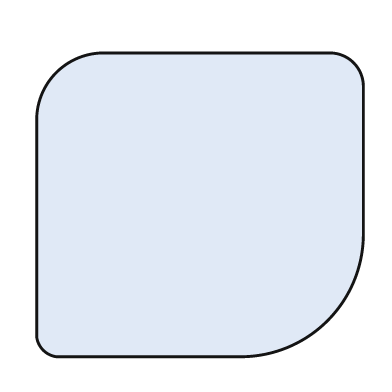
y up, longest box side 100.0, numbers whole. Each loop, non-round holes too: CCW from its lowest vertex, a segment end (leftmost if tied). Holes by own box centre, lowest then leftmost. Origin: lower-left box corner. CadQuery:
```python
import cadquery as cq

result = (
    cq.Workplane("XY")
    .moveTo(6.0, 0.0)
    .lineTo(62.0, 0.0)
    .threePointArc((89.0, 11.0), (100.0, 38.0))
    .lineTo(100.0, 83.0)
    .threePointArc((97.0, 90.0), (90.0, 93.0))
    .lineTo(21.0, 93.0)
    .threePointArc((6.0, 87.0), (0.0, 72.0))
    .lineTo(0.0, 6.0)
    .threePointArc((2.0, 2.0), (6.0, 0.0))
    .close()
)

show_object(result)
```